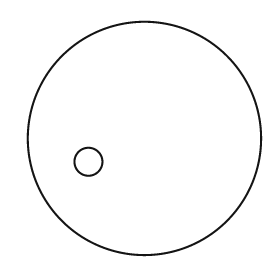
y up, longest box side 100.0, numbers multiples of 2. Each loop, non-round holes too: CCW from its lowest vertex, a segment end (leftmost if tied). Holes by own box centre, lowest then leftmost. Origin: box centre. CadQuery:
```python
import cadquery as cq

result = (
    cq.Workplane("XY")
    .moveTo(0.0, 0.0)
    .circle(50.0)
    .moveTo(-24.0, -10.0)
    .circle(6.0)
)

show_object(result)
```